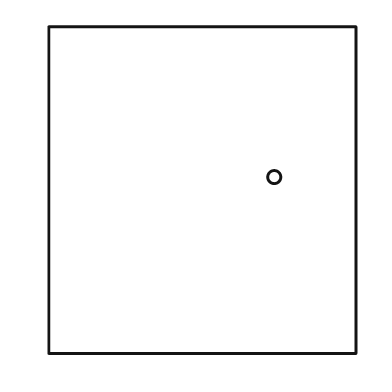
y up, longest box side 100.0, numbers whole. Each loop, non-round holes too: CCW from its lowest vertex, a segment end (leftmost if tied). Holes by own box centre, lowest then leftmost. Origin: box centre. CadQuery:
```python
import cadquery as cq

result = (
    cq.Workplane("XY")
    .moveTo(-47.0, -50.0)
    .lineTo(47.0, -50.0)
    .lineTo(47.0, 50.0)
    .lineTo(-47.0, 50.0)
    .close()
    .moveTo(22.0, 4.0)
    .circle(2.0)
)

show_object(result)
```